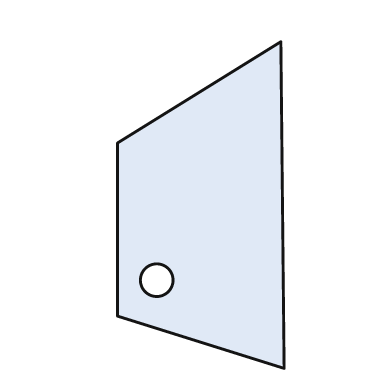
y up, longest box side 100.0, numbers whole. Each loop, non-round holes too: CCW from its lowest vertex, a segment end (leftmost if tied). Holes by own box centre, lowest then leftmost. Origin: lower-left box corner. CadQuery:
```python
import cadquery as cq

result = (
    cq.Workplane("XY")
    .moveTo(51.0, 0.0)
    .lineTo(50.0, 100.0)
    .lineTo(0.0, 69.0)
    .lineTo(0.0, 16.0)
    .close()
    .moveTo(12.0, 27.0)
    .circle(5.0)
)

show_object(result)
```